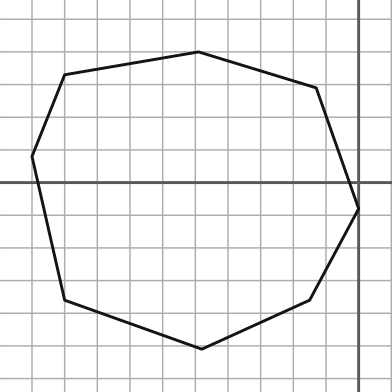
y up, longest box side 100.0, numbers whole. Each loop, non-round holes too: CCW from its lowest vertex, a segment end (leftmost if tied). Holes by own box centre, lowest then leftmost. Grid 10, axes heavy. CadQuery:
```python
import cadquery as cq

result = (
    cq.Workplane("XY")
    .moveTo(-48.0, -51.0)
    .lineTo(-15.0, -36.0)
    .lineTo(0.0, -8.0)
    .lineTo(-13.0, 29.0)
    .lineTo(-49.0, 40.0)
    .lineTo(-90.0, 33.0)
    .lineTo(-100.0, 8.0)
    .lineTo(-90.0, -36.0)
    .close()
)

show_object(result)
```